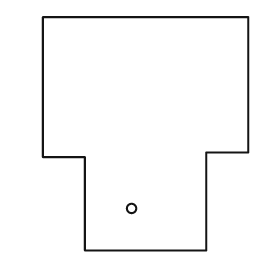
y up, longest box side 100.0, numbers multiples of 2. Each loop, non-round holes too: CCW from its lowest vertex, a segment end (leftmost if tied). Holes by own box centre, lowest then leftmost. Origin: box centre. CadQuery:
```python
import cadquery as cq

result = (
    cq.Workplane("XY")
    .moveTo(-26.0, -50.0)
    .lineTo(26.0, -50.0)
    .lineTo(26.0, -8.0)
    .lineTo(44.0, -8.0)
    .lineTo(44.0, 50.0)
    .lineTo(-44.0, 50.0)
    .lineTo(-44.0, -10.0)
    .lineTo(-26.0, -10.0)
    .close()
    .moveTo(-6.0, -32.0)
    .circle(2.0)
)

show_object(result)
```